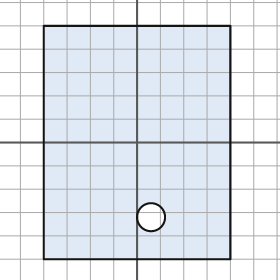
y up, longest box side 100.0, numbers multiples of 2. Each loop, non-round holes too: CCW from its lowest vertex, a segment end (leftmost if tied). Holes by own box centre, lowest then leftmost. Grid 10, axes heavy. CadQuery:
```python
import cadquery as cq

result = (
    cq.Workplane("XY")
    .moveTo(-40.0, -50.0)
    .lineTo(40.0, -50.0)
    .lineTo(40.0, 50.0)
    .lineTo(-40.0, 50.0)
    .close()
    .moveTo(6.0, -32.0)
    .circle(6.0)
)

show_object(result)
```